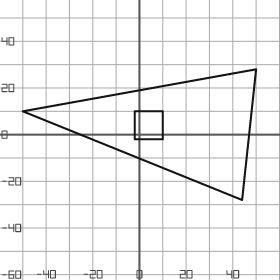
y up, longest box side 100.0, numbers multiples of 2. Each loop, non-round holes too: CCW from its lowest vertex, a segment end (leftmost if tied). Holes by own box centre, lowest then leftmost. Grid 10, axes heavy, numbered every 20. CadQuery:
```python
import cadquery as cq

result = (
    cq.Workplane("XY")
    .moveTo(44.0, -28.0)
    .lineTo(50.0, 28.0)
    .lineTo(-50.0, 10.0)
    .close()
    .moveTo(-2.0, -2.0)
    .lineTo(10.0, -2.0)
    .lineTo(10.0, 10.0)
    .lineTo(-2.0, 10.0)
    .close()
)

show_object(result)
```